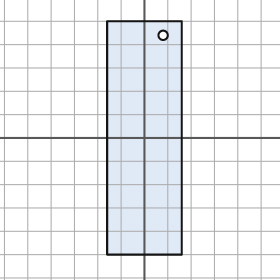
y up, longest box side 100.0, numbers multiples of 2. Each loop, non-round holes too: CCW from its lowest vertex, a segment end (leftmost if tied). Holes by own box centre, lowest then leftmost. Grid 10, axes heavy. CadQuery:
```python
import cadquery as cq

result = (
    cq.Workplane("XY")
    .moveTo(-16.0, -50.0)
    .lineTo(16.0, -50.0)
    .lineTo(16.0, 50.0)
    .lineTo(-16.0, 50.0)
    .close()
    .moveTo(8.0, 44.0)
    .circle(2.0)
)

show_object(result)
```